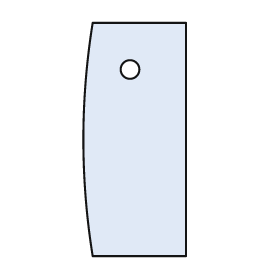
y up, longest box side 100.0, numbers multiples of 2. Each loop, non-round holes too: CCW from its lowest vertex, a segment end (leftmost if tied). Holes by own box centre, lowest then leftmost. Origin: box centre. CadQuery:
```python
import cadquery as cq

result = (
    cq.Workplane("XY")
    .moveTo(-18.0, -50.0)
    .lineTo(22.0, -50.0)
    .lineTo(22.0, 50.0)
    .lineTo(-18.0, 50.0)
    .threePointArc((-22.0, 0.0), (-18.0, -50.0))
    .close()
    .moveTo(-2.0, 30.0)
    .circle(4.0)
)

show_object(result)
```